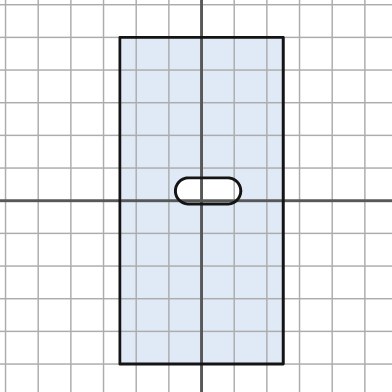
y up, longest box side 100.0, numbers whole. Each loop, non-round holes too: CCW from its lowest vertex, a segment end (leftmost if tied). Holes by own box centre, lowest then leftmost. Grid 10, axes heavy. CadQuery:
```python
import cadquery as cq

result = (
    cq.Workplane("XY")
    .moveTo(-25.0, -50.0)
    .lineTo(25.0, -50.0)
    .lineTo(25.0, 50.0)
    .lineTo(-25.0, 50.0)
    .close()
    .moveTo(-4.0, -1.0)
    .lineTo(8.0, -1.0)
    .threePointArc((12.0, 3.0), (8.0, 7.0))
    .lineTo(-4.0, 7.0)
    .threePointArc((-8.0, 3.0), (-4.0, -1.0))
    .close()
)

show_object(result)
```